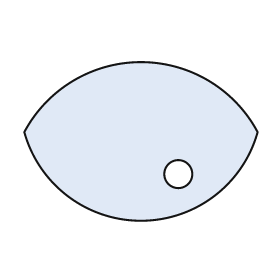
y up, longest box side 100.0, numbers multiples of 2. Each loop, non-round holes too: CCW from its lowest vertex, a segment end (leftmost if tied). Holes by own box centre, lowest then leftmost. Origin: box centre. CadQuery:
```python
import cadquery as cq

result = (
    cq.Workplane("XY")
    .moveTo(-50.0, 4.0)
    .threePointArc((0.0, -34.0), (50.0, 4.0))
    .threePointArc((0.0, 34.0), (-50.0, 4.0))
    .close()
    .moveTo(16.0, -14.0)
    .circle(6.0)
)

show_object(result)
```